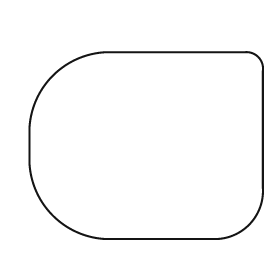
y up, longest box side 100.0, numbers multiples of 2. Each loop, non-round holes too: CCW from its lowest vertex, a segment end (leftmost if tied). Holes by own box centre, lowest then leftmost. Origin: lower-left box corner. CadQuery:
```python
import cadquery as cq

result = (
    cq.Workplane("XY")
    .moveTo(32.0, 0.0)
    .lineTo(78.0, 0.0)
    .threePointArc((94.0, 6.0), (100.0, 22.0))
    .lineTo(100.0, 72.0)
    .threePointArc((98.0, 78.0), (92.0, 80.0))
    .lineTo(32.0, 80.0)
    .threePointArc((10.0, 70.0), (0.0, 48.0))
    .lineTo(0.0, 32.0)
    .threePointArc((10.0, 10.0), (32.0, 0.0))
    .close()
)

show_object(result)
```